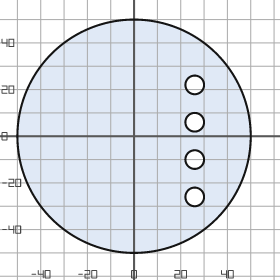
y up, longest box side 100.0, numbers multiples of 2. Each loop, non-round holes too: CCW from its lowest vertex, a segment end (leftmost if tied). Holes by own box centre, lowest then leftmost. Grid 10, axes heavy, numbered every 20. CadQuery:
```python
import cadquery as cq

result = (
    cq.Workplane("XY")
    .moveTo(0.0, 0.0)
    .circle(50.0)
    .moveTo(26.0, -26.0)
    .circle(4.0)
    .moveTo(26.0, -10.0)
    .circle(4.0)
    .moveTo(26.0, 6.0)
    .circle(4.0)
    .moveTo(26.0, 22.0)
    .circle(4.0)
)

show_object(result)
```